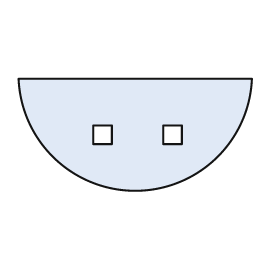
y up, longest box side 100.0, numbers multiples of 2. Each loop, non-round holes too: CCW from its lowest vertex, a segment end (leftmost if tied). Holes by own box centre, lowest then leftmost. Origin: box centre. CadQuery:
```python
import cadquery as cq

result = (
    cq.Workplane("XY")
    .moveTo(-50.0, 24.0)
    .threePointArc((0.0, -24.0), (50.0, 24.0))
    .close()
    .moveTo(-18.0, -4.0)
    .lineTo(-10.0, -4.0)
    .lineTo(-10.0, 4.0)
    .lineTo(-18.0, 4.0)
    .close()
    .moveTo(12.0, -4.0)
    .lineTo(20.0, -4.0)
    .lineTo(20.0, 4.0)
    .lineTo(12.0, 4.0)
    .close()
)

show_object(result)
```